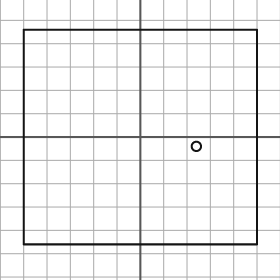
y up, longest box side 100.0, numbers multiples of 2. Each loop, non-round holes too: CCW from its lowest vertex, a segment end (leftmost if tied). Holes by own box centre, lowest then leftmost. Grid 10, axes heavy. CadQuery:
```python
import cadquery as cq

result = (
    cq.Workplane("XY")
    .moveTo(-50.0, -46.0)
    .lineTo(50.0, -46.0)
    .lineTo(50.0, 46.0)
    .lineTo(-50.0, 46.0)
    .close()
    .moveTo(24.0, -4.0)
    .circle(2.0)
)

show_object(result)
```